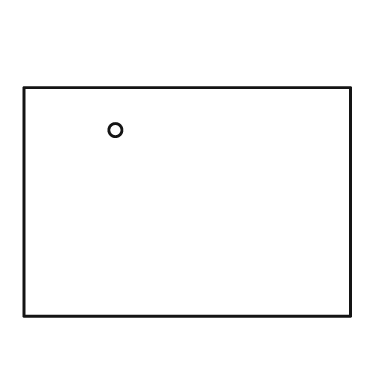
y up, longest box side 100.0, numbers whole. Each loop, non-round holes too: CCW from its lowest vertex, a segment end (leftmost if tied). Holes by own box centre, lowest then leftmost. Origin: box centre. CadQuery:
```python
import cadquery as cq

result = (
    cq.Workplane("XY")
    .moveTo(-50.0, -35.0)
    .lineTo(50.0, -35.0)
    .lineTo(50.0, 35.0)
    .lineTo(-50.0, 35.0)
    .close()
    .moveTo(-22.0, 22.0)
    .circle(2.0)
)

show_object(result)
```